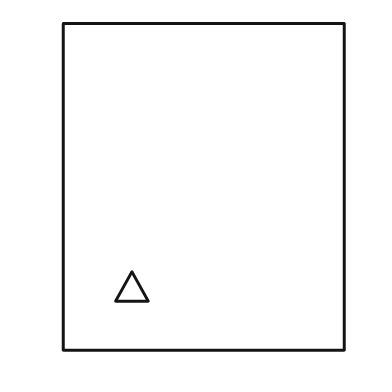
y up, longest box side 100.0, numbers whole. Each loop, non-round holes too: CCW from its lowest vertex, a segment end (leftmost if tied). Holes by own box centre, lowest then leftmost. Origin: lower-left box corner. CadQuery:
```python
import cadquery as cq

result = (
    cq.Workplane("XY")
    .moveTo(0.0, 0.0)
    .lineTo(86.0, 0.0)
    .lineTo(86.0, 100.0)
    .lineTo(0.0, 100.0)
    .close()
    .moveTo(16.0, 15.0)
    .lineTo(26.0, 15.0)
    .lineTo(21.0, 24.0)
    .close()
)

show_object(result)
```